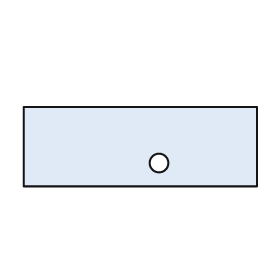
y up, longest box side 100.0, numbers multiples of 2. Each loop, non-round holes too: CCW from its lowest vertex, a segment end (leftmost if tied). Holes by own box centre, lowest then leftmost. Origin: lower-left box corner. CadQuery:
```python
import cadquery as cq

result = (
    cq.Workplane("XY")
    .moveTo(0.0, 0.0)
    .lineTo(100.0, 0.0)
    .lineTo(100.0, 34.0)
    .lineTo(0.0, 34.0)
    .close()
    .moveTo(58.0, 10.0)
    .circle(4.0)
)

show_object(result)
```